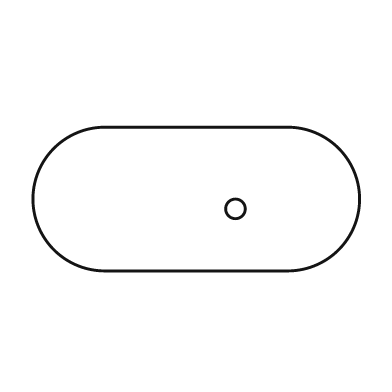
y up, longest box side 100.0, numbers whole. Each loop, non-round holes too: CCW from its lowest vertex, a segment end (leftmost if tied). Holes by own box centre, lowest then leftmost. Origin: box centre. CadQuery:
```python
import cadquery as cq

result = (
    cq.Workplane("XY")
    .moveTo(-28.0, -22.0)
    .lineTo(28.0, -22.0)
    .threePointArc((50.0, 0.0), (28.0, 22.0))
    .lineTo(-28.0, 22.0)
    .threePointArc((-50.0, 0.0), (-28.0, -22.0))
    .close()
    .moveTo(12.0, -3.0)
    .circle(3.0)
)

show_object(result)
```